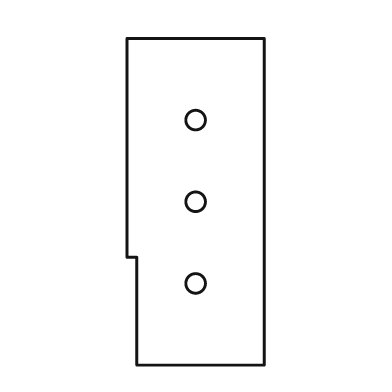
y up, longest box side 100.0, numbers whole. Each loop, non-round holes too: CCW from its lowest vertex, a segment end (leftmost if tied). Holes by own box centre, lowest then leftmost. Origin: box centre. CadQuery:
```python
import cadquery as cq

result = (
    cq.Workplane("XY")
    .moveTo(-18.0, -50.0)
    .lineTo(21.0, -50.0)
    .lineTo(21.0, 50.0)
    .lineTo(-21.0, 50.0)
    .lineTo(-21.0, -17.0)
    .lineTo(-18.0, -17.0)
    .close()
    .moveTo(0.0, -25.0)
    .circle(3.0)
    .moveTo(0.0, 0.0)
    .circle(3.0)
    .moveTo(0.0, 25.0)
    .circle(3.0)
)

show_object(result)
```